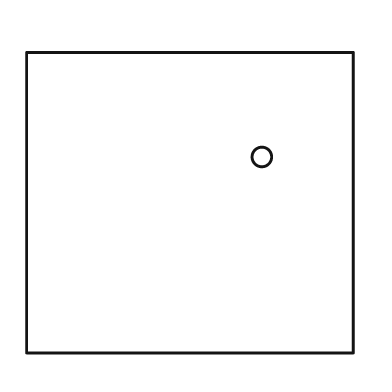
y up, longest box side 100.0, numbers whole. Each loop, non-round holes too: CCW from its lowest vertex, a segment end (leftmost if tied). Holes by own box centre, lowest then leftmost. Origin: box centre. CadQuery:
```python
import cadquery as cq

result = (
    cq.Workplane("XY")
    .moveTo(-50.0, -46.0)
    .lineTo(50.0, -46.0)
    .lineTo(50.0, 46.0)
    .lineTo(-50.0, 46.0)
    .close()
    .moveTo(22.0, 14.0)
    .circle(3.0)
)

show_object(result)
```